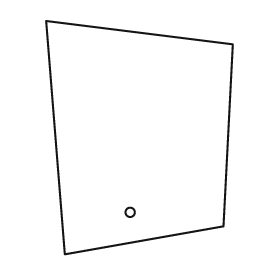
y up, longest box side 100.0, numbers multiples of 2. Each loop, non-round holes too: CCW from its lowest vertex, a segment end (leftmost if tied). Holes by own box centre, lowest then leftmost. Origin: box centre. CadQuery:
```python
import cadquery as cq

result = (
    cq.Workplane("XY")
    .moveTo(-32.0, -50.0)
    .lineTo(36.0, -38.0)
    .lineTo(40.0, 40.0)
    .lineTo(-40.0, 50.0)
    .close()
    .moveTo(-4.0, -32.0)
    .circle(2.0)
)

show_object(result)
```